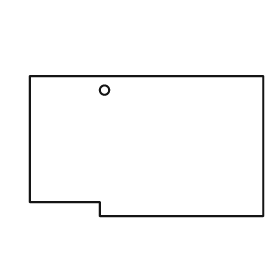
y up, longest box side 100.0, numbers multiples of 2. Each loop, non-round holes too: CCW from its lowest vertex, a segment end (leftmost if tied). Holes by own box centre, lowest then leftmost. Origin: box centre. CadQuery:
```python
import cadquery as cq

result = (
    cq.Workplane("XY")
    .moveTo(-20.0, -30.0)
    .lineTo(50.0, -30.0)
    .lineTo(50.0, 30.0)
    .lineTo(-50.0, 30.0)
    .lineTo(-50.0, -24.0)
    .lineTo(-20.0, -24.0)
    .close()
    .moveTo(-18.0, 24.0)
    .circle(2.0)
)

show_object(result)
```